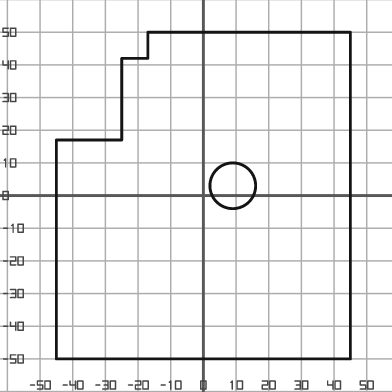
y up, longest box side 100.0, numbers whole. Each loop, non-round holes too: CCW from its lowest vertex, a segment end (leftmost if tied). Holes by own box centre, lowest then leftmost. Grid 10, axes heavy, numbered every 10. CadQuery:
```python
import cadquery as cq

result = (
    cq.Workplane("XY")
    .moveTo(-45.0, -50.0)
    .lineTo(45.0, -50.0)
    .lineTo(45.0, 50.0)
    .lineTo(-17.0, 50.0)
    .lineTo(-17.0, 42.0)
    .lineTo(-25.0, 42.0)
    .lineTo(-25.0, 17.0)
    .lineTo(-45.0, 17.0)
    .close()
    .moveTo(9.0, 3.0)
    .circle(7.0)
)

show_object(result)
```